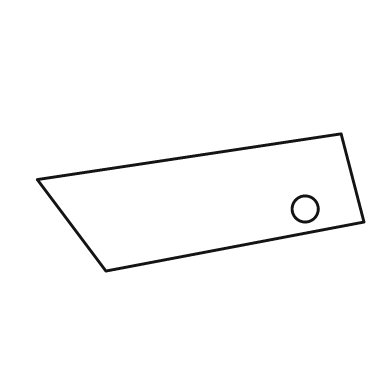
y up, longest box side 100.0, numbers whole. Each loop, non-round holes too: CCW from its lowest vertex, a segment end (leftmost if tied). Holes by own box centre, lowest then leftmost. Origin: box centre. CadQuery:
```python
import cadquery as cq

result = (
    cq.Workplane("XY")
    .moveTo(-29.0, -21.0)
    .lineTo(50.0, -6.0)
    .lineTo(43.0, 21.0)
    .lineTo(-50.0, 7.0)
    .close()
    .moveTo(32.0, -2.0)
    .circle(4.0)
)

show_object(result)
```